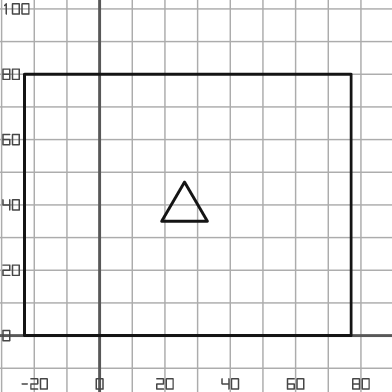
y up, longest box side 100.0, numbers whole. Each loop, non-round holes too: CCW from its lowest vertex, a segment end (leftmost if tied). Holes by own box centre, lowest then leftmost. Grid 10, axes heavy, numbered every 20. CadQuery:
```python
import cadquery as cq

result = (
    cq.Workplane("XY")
    .moveTo(-23.0, 0.0)
    .lineTo(77.0, 0.0)
    .lineTo(77.0, 80.0)
    .lineTo(-23.0, 80.0)
    .close()
    .moveTo(19.0, 35.0)
    .lineTo(33.0, 35.0)
    .lineTo(26.0, 47.0)
    .close()
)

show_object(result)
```